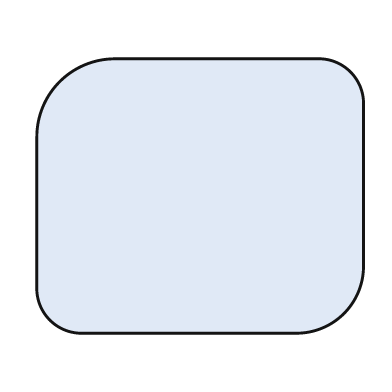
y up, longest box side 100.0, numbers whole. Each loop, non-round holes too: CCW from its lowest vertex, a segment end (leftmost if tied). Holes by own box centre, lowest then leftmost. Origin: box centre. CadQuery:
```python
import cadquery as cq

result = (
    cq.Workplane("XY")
    .moveTo(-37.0, -42.0)
    .lineTo(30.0, -42.0)
    .threePointArc((44.0, -36.0), (50.0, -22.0))
    .lineTo(50.0, 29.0)
    .threePointArc((46.0, 38.0), (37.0, 42.0))
    .lineTo(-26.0, 42.0)
    .threePointArc((-43.0, 35.0), (-50.0, 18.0))
    .lineTo(-50.0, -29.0)
    .threePointArc((-46.0, -38.0), (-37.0, -42.0))
    .close()
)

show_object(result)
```